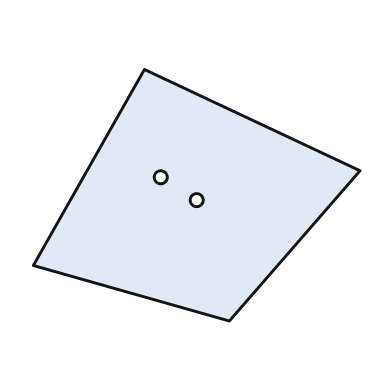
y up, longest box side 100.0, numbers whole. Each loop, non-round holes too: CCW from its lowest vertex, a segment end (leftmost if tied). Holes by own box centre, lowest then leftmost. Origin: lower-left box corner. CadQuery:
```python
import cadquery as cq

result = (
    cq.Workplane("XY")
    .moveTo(60.0, 0.0)
    .lineTo(100.0, 46.0)
    .lineTo(34.0, 77.0)
    .lineTo(0.0, 17.0)
    .close()
    .moveTo(50.0, 37.0)
    .circle(2.0)
    .moveTo(39.0, 44.0)
    .circle(2.0)
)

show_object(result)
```